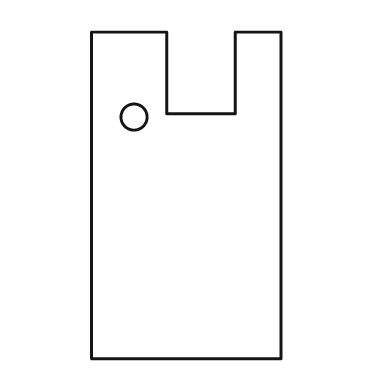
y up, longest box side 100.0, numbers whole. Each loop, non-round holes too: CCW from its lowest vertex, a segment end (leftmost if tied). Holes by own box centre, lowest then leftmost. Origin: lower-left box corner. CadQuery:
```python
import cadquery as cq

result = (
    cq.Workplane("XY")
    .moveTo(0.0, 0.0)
    .lineTo(58.0, 0.0)
    .lineTo(58.0, 100.0)
    .lineTo(44.0, 100.0)
    .lineTo(44.0, 75.0)
    .lineTo(23.0, 75.0)
    .lineTo(23.0, 100.0)
    .lineTo(0.0, 100.0)
    .close()
    .moveTo(13.0, 74.0)
    .circle(4.0)
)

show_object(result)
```